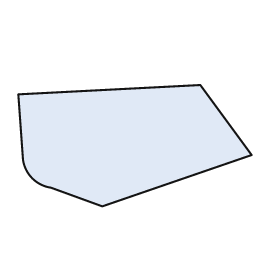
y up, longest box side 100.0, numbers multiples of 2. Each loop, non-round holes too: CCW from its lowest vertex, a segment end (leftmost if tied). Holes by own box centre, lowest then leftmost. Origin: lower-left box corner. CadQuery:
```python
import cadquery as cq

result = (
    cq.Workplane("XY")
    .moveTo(36.0, 0.0)
    .lineTo(100.0, 22.0)
    .lineTo(78.0, 52.0)
    .lineTo(0.0, 48.0)
    .lineTo(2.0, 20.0)
    .threePointArc((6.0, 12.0), (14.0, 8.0))
    .close()
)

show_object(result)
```